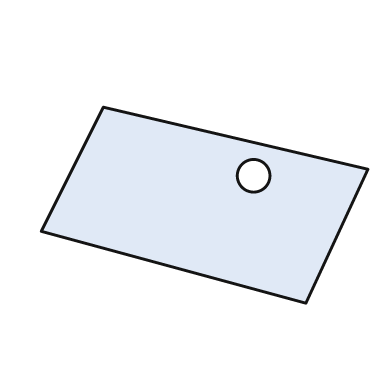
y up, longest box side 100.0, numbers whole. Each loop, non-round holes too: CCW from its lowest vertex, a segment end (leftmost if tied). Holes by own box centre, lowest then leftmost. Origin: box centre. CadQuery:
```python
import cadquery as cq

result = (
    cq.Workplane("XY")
    .moveTo(31.0, -30.0)
    .lineTo(50.0, 11.0)
    .lineTo(-31.0, 30.0)
    .lineTo(-50.0, -8.0)
    .close()
    .moveTo(15.0, 9.0)
    .circle(5.0)
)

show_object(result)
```